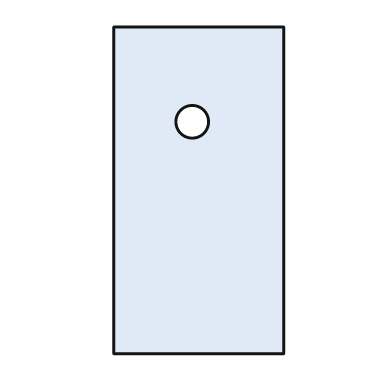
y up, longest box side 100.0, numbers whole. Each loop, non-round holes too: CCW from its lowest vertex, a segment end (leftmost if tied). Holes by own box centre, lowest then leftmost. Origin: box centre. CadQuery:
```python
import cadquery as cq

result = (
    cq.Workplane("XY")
    .moveTo(-26.0, -50.0)
    .lineTo(26.0, -50.0)
    .lineTo(26.0, 50.0)
    .lineTo(-26.0, 50.0)
    .close()
    .moveTo(-2.0, 21.0)
    .circle(5.0)
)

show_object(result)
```